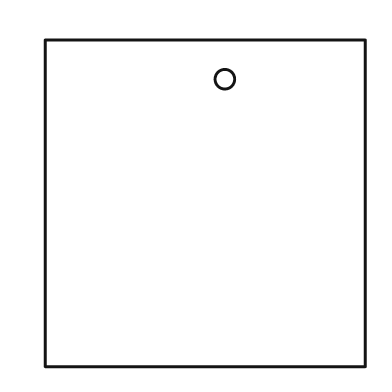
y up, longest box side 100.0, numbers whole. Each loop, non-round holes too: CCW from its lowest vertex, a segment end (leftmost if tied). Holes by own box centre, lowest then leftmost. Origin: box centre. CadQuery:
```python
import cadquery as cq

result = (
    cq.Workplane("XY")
    .moveTo(-49.0, -50.0)
    .lineTo(49.0, -50.0)
    .lineTo(49.0, 50.0)
    .lineTo(-49.0, 50.0)
    .close()
    .moveTo(6.0, 38.0)
    .circle(3.0)
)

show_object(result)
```